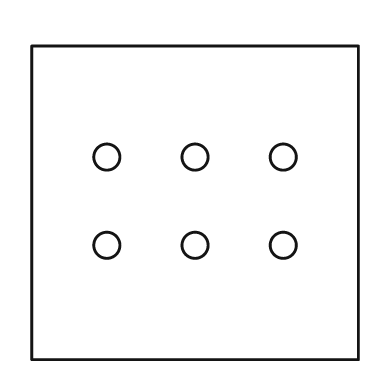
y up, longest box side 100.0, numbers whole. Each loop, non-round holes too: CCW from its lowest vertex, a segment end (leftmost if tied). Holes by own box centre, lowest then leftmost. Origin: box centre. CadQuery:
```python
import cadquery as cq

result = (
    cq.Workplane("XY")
    .moveTo(-50.0, -48.0)
    .lineTo(50.0, -48.0)
    .lineTo(50.0, 48.0)
    .lineTo(-50.0, 48.0)
    .close()
    .moveTo(-27.0, -13.0)
    .circle(4.0)
    .moveTo(0.0, -13.0)
    .circle(4.0)
    .moveTo(27.0, -13.0)
    .circle(4.0)
    .moveTo(-27.0, 14.0)
    .circle(4.0)
    .moveTo(0.0, 14.0)
    .circle(4.0)
    .moveTo(27.0, 14.0)
    .circle(4.0)
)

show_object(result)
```